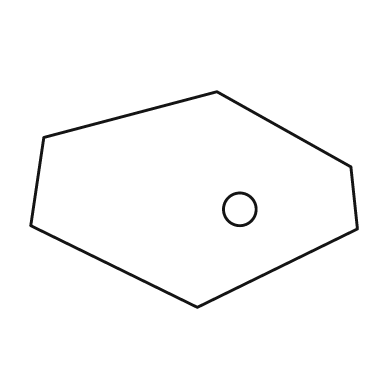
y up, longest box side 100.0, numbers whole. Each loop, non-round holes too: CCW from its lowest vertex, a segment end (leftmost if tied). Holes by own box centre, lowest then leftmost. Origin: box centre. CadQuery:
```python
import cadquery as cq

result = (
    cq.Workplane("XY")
    .moveTo(1.0, -33.0)
    .lineTo(50.0, -9.0)
    .lineTo(48.0, 10.0)
    .lineTo(7.0, 33.0)
    .lineTo(-46.0, 19.0)
    .lineTo(-50.0, -8.0)
    .close()
    .moveTo(14.0, -3.0)
    .circle(5.0)
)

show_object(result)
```